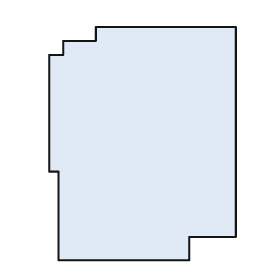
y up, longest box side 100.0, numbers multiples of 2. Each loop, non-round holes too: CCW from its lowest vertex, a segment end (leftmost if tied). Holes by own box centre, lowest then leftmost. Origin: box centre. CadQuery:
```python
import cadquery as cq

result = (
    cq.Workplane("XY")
    .moveTo(-36.0, -50.0)
    .lineTo(20.0, -50.0)
    .lineTo(20.0, -40.0)
    .lineTo(40.0, -40.0)
    .lineTo(40.0, 50.0)
    .lineTo(-20.0, 50.0)
    .lineTo(-20.0, 44.0)
    .lineTo(-34.0, 44.0)
    .lineTo(-34.0, 38.0)
    .lineTo(-40.0, 38.0)
    .lineTo(-40.0, -12.0)
    .lineTo(-36.0, -12.0)
    .close()
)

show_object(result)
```